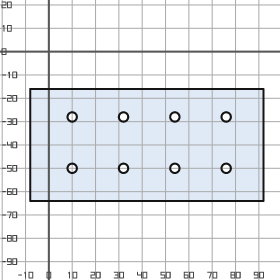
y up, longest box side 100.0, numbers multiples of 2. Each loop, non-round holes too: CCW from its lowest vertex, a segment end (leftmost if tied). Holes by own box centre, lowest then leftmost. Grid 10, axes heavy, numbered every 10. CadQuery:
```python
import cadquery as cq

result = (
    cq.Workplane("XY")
    .moveTo(-8.0, -64.0)
    .lineTo(92.0, -64.0)
    .lineTo(92.0, -16.0)
    .lineTo(-8.0, -16.0)
    .close()
    .moveTo(10.0, -50.0)
    .circle(2.0)
    .moveTo(32.0, -50.0)
    .circle(2.0)
    .moveTo(54.0, -50.0)
    .circle(2.0)
    .moveTo(76.0, -50.0)
    .circle(2.0)
    .moveTo(10.0, -28.0)
    .circle(2.0)
    .moveTo(32.0, -28.0)
    .circle(2.0)
    .moveTo(54.0, -28.0)
    .circle(2.0)
    .moveTo(76.0, -28.0)
    .circle(2.0)
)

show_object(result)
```